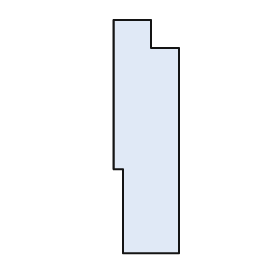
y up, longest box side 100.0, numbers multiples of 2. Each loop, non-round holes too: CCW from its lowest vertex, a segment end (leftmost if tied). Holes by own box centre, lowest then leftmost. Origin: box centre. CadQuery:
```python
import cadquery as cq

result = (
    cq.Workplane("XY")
    .moveTo(-10.0, -50.0)
    .lineTo(14.0, -50.0)
    .lineTo(14.0, 38.0)
    .lineTo(2.0, 38.0)
    .lineTo(2.0, 50.0)
    .lineTo(-14.0, 50.0)
    .lineTo(-14.0, -14.0)
    .lineTo(-10.0, -14.0)
    .close()
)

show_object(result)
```